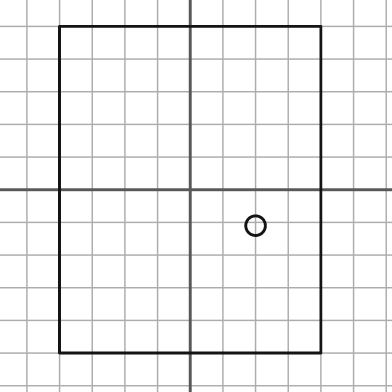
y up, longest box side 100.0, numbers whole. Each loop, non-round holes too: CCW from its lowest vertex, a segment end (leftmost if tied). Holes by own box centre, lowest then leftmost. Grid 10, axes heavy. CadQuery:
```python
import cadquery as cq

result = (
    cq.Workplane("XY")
    .moveTo(-40.0, -50.0)
    .lineTo(40.0, -50.0)
    .lineTo(40.0, 50.0)
    .lineTo(-40.0, 50.0)
    .close()
    .moveTo(20.0, -11.0)
    .circle(3.0)
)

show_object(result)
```